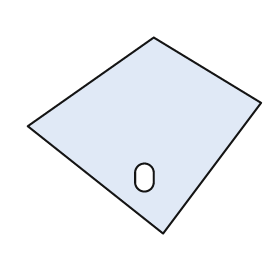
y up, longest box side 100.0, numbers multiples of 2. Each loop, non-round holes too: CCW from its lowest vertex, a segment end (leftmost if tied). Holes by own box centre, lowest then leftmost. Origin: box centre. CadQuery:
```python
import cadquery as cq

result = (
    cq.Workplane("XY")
    .moveTo(8.0, -42.0)
    .lineTo(50.0, 14.0)
    .lineTo(4.0, 42.0)
    .lineTo(-50.0, 4.0)
    .close()
    .moveTo(-4.0, -20.0)
    .threePointArc((0.0, -24.0), (4.0, -20.0))
    .lineTo(4.0, -16.0)
    .threePointArc((0.0, -12.0), (-4.0, -16.0))
    .close()
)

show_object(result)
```